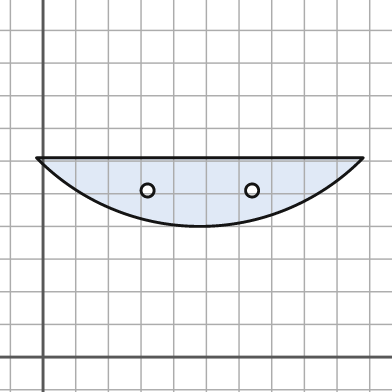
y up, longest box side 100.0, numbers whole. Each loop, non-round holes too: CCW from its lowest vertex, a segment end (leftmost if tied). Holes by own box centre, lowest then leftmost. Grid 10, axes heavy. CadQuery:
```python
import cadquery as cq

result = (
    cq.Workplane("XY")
    .moveTo(-2.0, 61.0)
    .threePointArc((48.0, 40.0), (98.0, 61.0))
    .close()
    .moveTo(32.0, 51.0)
    .circle(2.0)
    .moveTo(64.0, 51.0)
    .circle(2.0)
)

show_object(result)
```